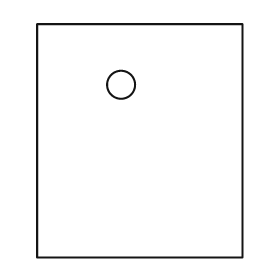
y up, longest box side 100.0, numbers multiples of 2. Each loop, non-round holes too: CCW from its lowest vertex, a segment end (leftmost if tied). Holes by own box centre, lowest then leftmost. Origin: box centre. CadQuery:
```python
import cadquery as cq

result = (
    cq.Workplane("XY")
    .moveTo(-44.0, -50.0)
    .lineTo(44.0, -50.0)
    .lineTo(44.0, 50.0)
    .lineTo(-44.0, 50.0)
    .close()
    .moveTo(-8.0, 24.0)
    .circle(6.0)
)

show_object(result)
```